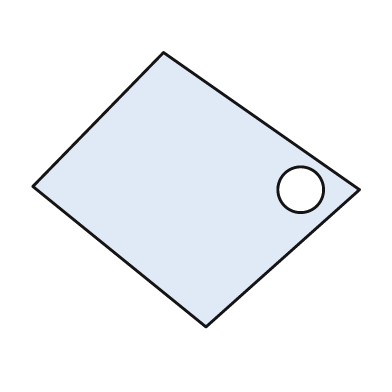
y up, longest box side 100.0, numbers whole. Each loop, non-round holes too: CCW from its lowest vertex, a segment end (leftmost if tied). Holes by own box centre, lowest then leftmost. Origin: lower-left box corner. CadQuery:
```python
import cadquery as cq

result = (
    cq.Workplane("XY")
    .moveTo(53.0, 0.0)
    .lineTo(100.0, 42.0)
    .lineTo(40.0, 84.0)
    .lineTo(0.0, 43.0)
    .close()
    .moveTo(82.0, 42.0)
    .circle(7.0)
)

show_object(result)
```